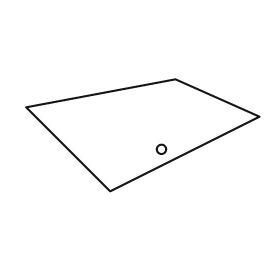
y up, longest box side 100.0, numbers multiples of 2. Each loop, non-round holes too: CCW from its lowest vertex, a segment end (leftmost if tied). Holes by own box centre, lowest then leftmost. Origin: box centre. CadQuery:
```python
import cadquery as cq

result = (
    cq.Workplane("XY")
    .moveTo(-14.0, -24.0)
    .lineTo(50.0, 8.0)
    .lineTo(14.0, 24.0)
    .lineTo(-50.0, 12.0)
    .close()
    .moveTo(8.0, -6.0)
    .circle(2.0)
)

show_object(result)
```